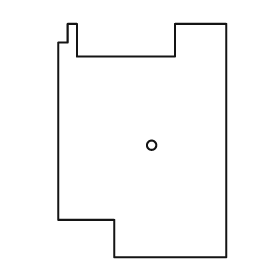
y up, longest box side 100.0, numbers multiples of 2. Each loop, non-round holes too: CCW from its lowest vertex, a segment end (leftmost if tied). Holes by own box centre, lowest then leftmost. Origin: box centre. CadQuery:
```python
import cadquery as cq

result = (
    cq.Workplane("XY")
    .moveTo(-12.0, -50.0)
    .lineTo(36.0, -50.0)
    .lineTo(36.0, 50.0)
    .lineTo(14.0, 50.0)
    .lineTo(14.0, 36.0)
    .lineTo(-28.0, 36.0)
    .lineTo(-28.0, 50.0)
    .lineTo(-32.0, 50.0)
    .lineTo(-32.0, 42.0)
    .lineTo(-36.0, 42.0)
    .lineTo(-36.0, -34.0)
    .lineTo(-12.0, -34.0)
    .close()
    .moveTo(4.0, -2.0)
    .circle(2.0)
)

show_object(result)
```